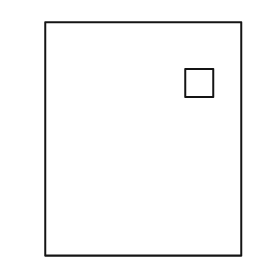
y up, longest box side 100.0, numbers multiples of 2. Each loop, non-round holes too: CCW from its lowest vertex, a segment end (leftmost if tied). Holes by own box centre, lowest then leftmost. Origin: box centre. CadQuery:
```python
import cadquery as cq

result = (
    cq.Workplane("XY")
    .moveTo(-42.0, -50.0)
    .lineTo(42.0, -50.0)
    .lineTo(42.0, 50.0)
    .lineTo(-42.0, 50.0)
    .close()
    .moveTo(18.0, 18.0)
    .lineTo(30.0, 18.0)
    .lineTo(30.0, 30.0)
    .lineTo(18.0, 30.0)
    .close()
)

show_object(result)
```